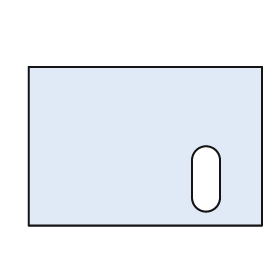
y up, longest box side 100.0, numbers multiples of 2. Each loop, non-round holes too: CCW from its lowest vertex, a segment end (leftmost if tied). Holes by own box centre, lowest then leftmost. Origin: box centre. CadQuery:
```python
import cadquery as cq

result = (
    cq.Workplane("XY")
    .moveTo(-50.0, -34.0)
    .lineTo(50.0, -34.0)
    .lineTo(50.0, 34.0)
    .lineTo(-50.0, 34.0)
    .close()
    .moveTo(20.0, -22.0)
    .threePointArc((26.0, -28.0), (32.0, -22.0))
    .lineTo(32.0, -6.0)
    .threePointArc((26.0, 0.0), (20.0, -6.0))
    .close()
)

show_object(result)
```